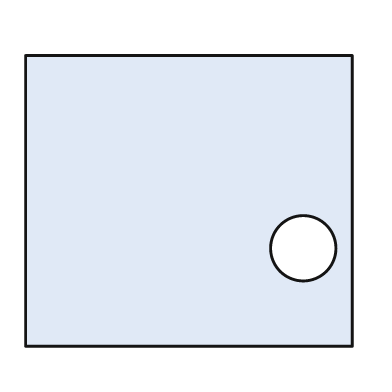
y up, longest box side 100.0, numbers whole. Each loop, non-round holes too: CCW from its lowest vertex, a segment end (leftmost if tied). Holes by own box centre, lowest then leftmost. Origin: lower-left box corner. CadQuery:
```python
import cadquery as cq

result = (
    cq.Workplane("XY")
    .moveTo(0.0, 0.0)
    .lineTo(100.0, 0.0)
    .lineTo(100.0, 89.0)
    .lineTo(0.0, 89.0)
    .close()
    .moveTo(85.0, 30.0)
    .circle(10.0)
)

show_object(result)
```